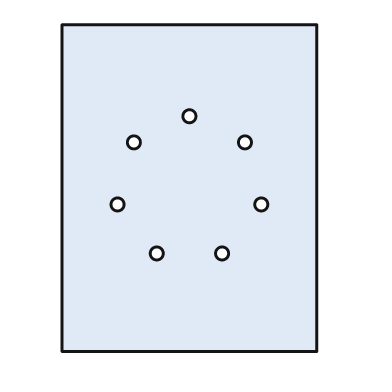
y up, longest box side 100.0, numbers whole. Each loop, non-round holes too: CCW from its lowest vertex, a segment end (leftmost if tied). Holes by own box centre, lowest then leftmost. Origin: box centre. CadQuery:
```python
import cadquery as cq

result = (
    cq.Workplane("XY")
    .moveTo(-39.0, -50.0)
    .lineTo(39.0, -50.0)
    .lineTo(39.0, 50.0)
    .lineTo(-39.0, 50.0)
    .close()
    .moveTo(-10.0, -20.0)
    .circle(2.0)
    .moveTo(10.0, -20.0)
    .circle(2.0)
    .moveTo(-22.0, -5.0)
    .circle(2.0)
    .moveTo(22.0, -5.0)
    .circle(2.0)
    .moveTo(-17.0, 14.0)
    .circle(2.0)
    .moveTo(17.0, 14.0)
    .circle(2.0)
    .moveTo(0.0, 22.0)
    .circle(2.0)
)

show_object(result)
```